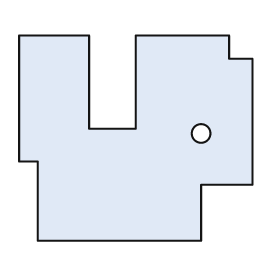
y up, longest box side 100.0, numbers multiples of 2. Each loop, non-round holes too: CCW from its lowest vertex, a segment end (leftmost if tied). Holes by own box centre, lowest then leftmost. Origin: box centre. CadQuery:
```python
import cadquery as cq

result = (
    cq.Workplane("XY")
    .moveTo(-42.0, -44.0)
    .lineTo(28.0, -44.0)
    .lineTo(28.0, -20.0)
    .lineTo(50.0, -20.0)
    .lineTo(50.0, 34.0)
    .lineTo(40.0, 34.0)
    .lineTo(40.0, 44.0)
    .lineTo(0.0, 44.0)
    .lineTo(0.0, 4.0)
    .lineTo(-20.0, 4.0)
    .lineTo(-20.0, 44.0)
    .lineTo(-50.0, 44.0)
    .lineTo(-50.0, -10.0)
    .lineTo(-42.0, -10.0)
    .close()
    .moveTo(28.0, 2.0)
    .circle(4.0)
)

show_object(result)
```